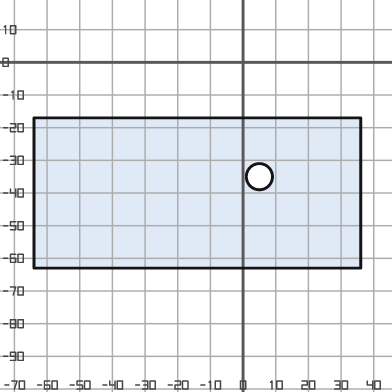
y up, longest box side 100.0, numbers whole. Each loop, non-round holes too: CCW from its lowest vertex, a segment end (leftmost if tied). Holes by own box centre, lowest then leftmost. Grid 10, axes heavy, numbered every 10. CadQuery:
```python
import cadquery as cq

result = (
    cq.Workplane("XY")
    .moveTo(-64.0, -63.0)
    .lineTo(36.0, -63.0)
    .lineTo(36.0, -17.0)
    .lineTo(-64.0, -17.0)
    .close()
    .moveTo(5.0, -35.0)
    .circle(4.0)
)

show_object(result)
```